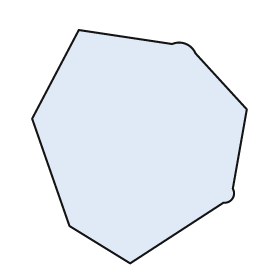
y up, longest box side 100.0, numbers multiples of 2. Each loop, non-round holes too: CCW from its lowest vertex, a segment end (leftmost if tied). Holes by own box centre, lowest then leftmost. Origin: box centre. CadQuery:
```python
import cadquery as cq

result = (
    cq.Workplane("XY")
    .moveTo(-4.0, -50.0)
    .lineTo(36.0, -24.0)
    .threePointArc((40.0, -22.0), (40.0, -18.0))
    .lineTo(46.0, 16.0)
    .lineTo(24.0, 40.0)
    .threePointArc((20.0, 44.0), (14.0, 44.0))
    .lineTo(-26.0, 50.0)
    .lineTo(-46.0, 12.0)
    .lineTo(-30.0, -34.0)
    .close()
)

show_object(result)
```